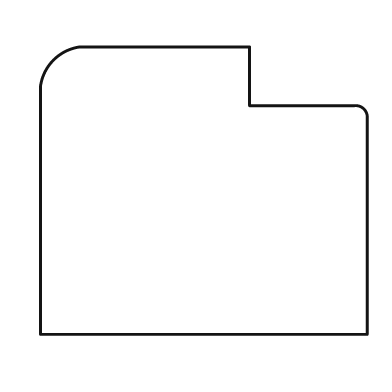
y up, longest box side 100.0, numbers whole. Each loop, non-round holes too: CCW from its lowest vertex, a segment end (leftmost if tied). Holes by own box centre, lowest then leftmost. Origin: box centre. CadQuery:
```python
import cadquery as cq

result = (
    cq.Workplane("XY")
    .moveTo(-50.0, -44.0)
    .lineTo(50.0, -44.0)
    .lineTo(50.0, 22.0)
    .threePointArc((49.0, 25.0), (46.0, 26.0))
    .lineTo(14.0, 26.0)
    .lineTo(14.0, 44.0)
    .lineTo(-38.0, 44.0)
    .threePointArc((-46.0, 40.0), (-50.0, 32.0))
    .close()
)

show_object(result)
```